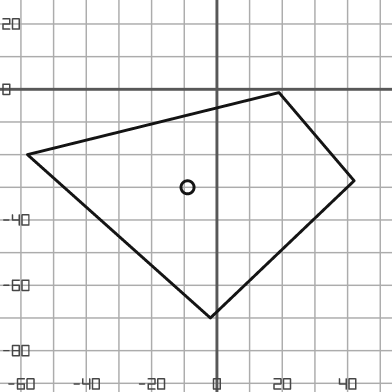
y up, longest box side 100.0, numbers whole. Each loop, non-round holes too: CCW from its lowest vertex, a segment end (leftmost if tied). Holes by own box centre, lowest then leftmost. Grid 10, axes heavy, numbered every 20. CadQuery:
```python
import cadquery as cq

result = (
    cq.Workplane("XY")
    .moveTo(-2.0, -70.0)
    .lineTo(42.0, -28.0)
    .lineTo(19.0, -1.0)
    .lineTo(-58.0, -20.0)
    .close()
    .moveTo(-9.0, -30.0)
    .circle(2.0)
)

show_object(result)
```